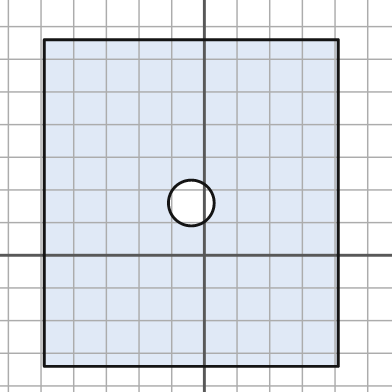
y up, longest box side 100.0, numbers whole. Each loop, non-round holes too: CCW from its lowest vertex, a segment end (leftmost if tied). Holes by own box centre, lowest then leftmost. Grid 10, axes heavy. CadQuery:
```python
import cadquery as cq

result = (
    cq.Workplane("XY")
    .moveTo(-49.0, -34.0)
    .lineTo(41.0, -34.0)
    .lineTo(41.0, 66.0)
    .lineTo(-49.0, 66.0)
    .close()
    .moveTo(-4.0, 16.0)
    .circle(7.0)
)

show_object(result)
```